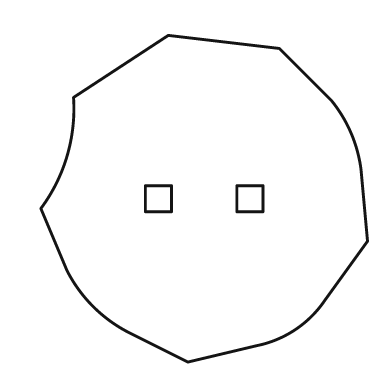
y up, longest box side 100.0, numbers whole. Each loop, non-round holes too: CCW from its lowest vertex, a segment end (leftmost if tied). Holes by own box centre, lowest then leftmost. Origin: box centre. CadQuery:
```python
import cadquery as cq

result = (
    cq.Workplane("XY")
    .moveTo(-5.0, -50.0)
    .lineTo(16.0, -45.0)
    .threePointArc((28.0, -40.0), (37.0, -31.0))
    .lineTo(50.0, -13.0)
    .lineTo(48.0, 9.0)
    .threePointArc((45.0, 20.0), (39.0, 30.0))
    .lineTo(23.0, 46.0)
    .lineTo(-11.0, 50.0)
    .lineTo(-40.0, 31.0)
    .threePointArc((-42.0, 13.0), (-50.0, -3.0))
    .lineTo(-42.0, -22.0)
    .threePointArc((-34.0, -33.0), (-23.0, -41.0))
    .close()
    .moveTo(-18.0, -4.0)
    .lineTo(-10.0, -4.0)
    .lineTo(-10.0, 4.0)
    .lineTo(-18.0, 4.0)
    .close()
    .moveTo(10.0, -4.0)
    .lineTo(18.0, -4.0)
    .lineTo(18.0, 4.0)
    .lineTo(10.0, 4.0)
    .close()
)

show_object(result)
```